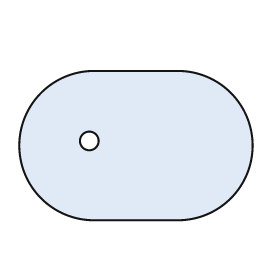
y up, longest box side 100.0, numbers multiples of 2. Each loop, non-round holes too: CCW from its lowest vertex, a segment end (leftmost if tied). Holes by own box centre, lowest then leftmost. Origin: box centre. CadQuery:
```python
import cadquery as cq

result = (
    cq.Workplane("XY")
    .moveTo(-18.0, -32.0)
    .lineTo(18.0, -32.0)
    .threePointArc((50.0, 0.0), (18.0, 32.0))
    .lineTo(-18.0, 32.0)
    .threePointArc((-50.0, 0.0), (-18.0, -32.0))
    .close()
    .moveTo(-20.0, 2.0)
    .circle(4.0)
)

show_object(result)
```